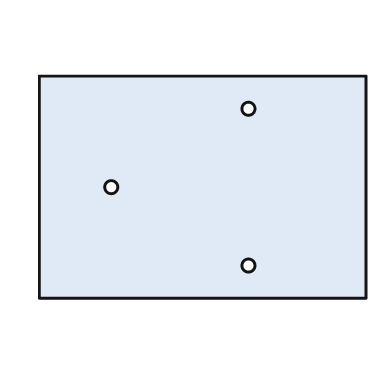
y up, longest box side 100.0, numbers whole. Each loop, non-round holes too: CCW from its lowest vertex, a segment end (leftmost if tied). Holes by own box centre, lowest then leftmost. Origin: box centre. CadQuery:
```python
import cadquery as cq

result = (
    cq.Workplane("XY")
    .moveTo(-50.0, -34.0)
    .lineTo(50.0, -34.0)
    .lineTo(50.0, 34.0)
    .lineTo(-50.0, 34.0)
    .close()
    .moveTo(14.0, -24.0)
    .circle(2.0)
    .moveTo(-28.0, 0.0)
    .circle(2.0)
    .moveTo(14.0, 24.0)
    .circle(2.0)
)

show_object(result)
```